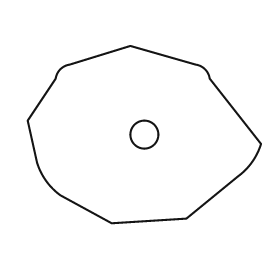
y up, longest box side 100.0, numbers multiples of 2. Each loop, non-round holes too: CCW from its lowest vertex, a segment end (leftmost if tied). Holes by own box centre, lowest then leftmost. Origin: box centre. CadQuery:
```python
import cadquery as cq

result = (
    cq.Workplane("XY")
    .moveTo(-14.0, -38.0)
    .lineTo(18.0, -36.0)
    .lineTo(40.0, -18.0)
    .threePointArc((46.0, -12.0), (50.0, -4.0))
    .lineTo(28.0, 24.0)
    .threePointArc((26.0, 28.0), (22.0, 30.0))
    .lineTo(-6.0, 38.0)
    .lineTo(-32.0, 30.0)
    .threePointArc((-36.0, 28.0), (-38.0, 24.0))
    .lineTo(-50.0, 6.0)
    .lineTo(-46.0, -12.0)
    .threePointArc((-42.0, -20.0), (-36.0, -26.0))
    .close()
    .moveTo(0.0, 0.0)
    .circle(6.0)
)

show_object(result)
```